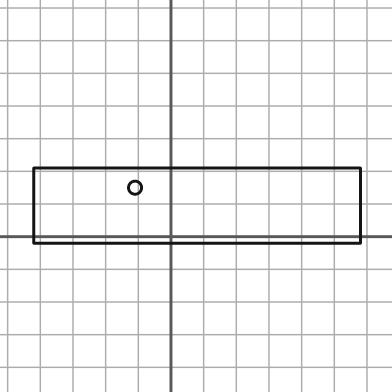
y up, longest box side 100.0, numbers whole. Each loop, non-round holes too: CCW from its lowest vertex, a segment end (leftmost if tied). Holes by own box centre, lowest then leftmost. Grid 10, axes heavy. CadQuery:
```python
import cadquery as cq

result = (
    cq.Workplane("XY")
    .moveTo(-42.0, -2.0)
    .lineTo(58.0, -2.0)
    .lineTo(58.0, 21.0)
    .lineTo(-42.0, 21.0)
    .close()
    .moveTo(-11.0, 15.0)
    .circle(2.0)
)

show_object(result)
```